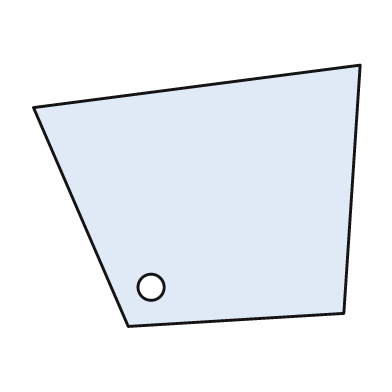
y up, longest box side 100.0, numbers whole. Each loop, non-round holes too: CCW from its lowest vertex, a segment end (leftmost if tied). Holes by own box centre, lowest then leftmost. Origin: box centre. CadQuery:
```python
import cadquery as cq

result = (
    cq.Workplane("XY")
    .moveTo(-21.0, -40.0)
    .lineTo(45.0, -36.0)
    .lineTo(50.0, 40.0)
    .lineTo(-50.0, 27.0)
    .close()
    .moveTo(-14.0, -28.0)
    .circle(4.0)
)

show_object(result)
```